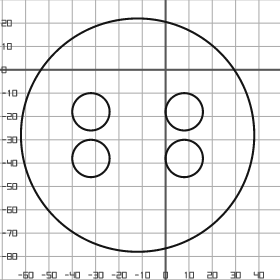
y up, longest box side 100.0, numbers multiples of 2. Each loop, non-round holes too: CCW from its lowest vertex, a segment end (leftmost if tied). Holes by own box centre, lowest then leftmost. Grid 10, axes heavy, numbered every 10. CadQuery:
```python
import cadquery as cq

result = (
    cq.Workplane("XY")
    .moveTo(-12.0, -28.0)
    .circle(50.0)
    .moveTo(-32.0, -38.0)
    .circle(8.0)
    .moveTo(8.0, -38.0)
    .circle(8.0)
    .moveTo(-32.0, -18.0)
    .circle(8.0)
    .moveTo(8.0, -18.0)
    .circle(8.0)
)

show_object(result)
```